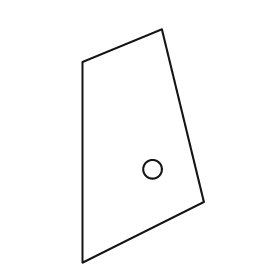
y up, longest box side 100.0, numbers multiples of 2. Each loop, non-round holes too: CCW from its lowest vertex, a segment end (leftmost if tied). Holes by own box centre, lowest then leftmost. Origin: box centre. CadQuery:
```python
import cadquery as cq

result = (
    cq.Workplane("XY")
    .moveTo(-26.0, -50.0)
    .lineTo(26.0, -24.0)
    .lineTo(8.0, 50.0)
    .lineTo(-26.0, 36.0)
    .close()
    .moveTo(4.0, -10.0)
    .circle(4.0)
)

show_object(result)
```